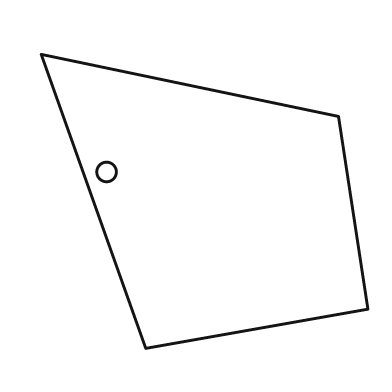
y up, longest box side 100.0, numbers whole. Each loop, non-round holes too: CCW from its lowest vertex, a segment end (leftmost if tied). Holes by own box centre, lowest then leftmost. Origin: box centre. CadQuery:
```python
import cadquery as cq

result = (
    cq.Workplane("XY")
    .moveTo(-18.0, -45.0)
    .lineTo(50.0, -33.0)
    .lineTo(41.0, 26.0)
    .lineTo(-50.0, 45.0)
    .close()
    .moveTo(-30.0, 9.0)
    .circle(3.0)
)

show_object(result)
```